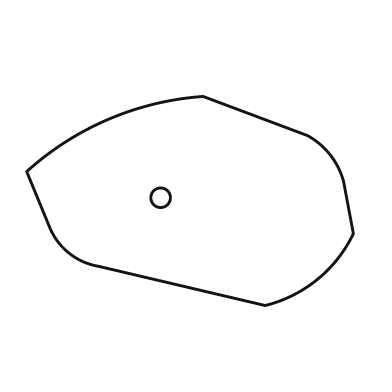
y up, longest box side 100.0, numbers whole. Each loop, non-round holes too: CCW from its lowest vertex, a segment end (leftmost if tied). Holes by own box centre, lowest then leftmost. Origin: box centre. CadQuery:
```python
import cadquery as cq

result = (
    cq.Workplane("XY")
    .moveTo(23.0, -32.0)
    .threePointArc((39.0, -24.0), (50.0, -10.0))
    .lineTo(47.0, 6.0)
    .threePointArc((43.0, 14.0), (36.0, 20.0))
    .lineTo(4.0, 32.0)
    .threePointArc((-25.0, 25.0), (-50.0, 9.0))
    .lineTo(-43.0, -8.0)
    .threePointArc((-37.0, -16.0), (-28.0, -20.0))
    .close()
    .moveTo(-9.0, 1.0)
    .circle(3.0)
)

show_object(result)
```